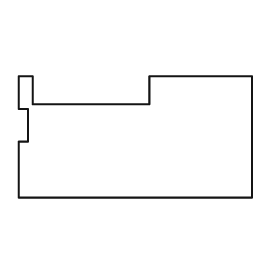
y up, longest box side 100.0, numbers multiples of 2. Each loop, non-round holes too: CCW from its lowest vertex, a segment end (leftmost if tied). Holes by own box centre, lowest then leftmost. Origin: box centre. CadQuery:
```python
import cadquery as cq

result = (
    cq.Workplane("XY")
    .moveTo(-50.0, -26.0)
    .lineTo(50.0, -26.0)
    .lineTo(50.0, 26.0)
    .lineTo(6.0, 26.0)
    .lineTo(6.0, 14.0)
    .lineTo(-44.0, 14.0)
    .lineTo(-44.0, 26.0)
    .lineTo(-50.0, 26.0)
    .lineTo(-50.0, 12.0)
    .lineTo(-46.0, 12.0)
    .lineTo(-46.0, -2.0)
    .lineTo(-50.0, -2.0)
    .close()
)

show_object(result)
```